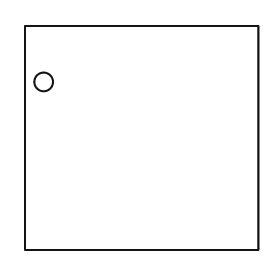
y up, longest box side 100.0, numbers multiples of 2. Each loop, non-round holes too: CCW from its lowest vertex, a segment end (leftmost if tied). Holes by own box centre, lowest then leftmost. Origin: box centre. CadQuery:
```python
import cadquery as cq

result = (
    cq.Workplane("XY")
    .moveTo(-50.0, -48.0)
    .lineTo(50.0, -48.0)
    .lineTo(50.0, 48.0)
    .lineTo(-50.0, 48.0)
    .close()
    .moveTo(-42.0, 24.0)
    .circle(4.0)
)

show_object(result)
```